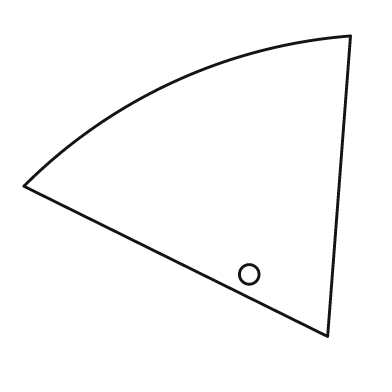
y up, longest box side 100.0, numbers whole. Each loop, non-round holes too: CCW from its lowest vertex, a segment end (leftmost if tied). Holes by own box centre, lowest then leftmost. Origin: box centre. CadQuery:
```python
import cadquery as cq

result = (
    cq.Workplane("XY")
    .moveTo(43.0, -46.0)
    .lineTo(50.0, 46.0)
    .threePointArc((-4.0, 32.0), (-50.0, 0.0))
    .close()
    .moveTo(19.0, -27.0)
    .circle(3.0)
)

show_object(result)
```